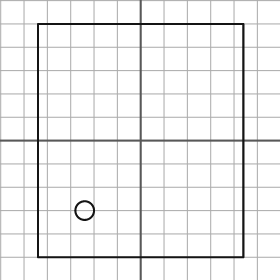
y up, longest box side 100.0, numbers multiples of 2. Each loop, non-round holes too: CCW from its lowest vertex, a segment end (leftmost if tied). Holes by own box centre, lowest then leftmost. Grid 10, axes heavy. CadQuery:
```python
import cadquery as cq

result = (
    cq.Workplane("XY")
    .moveTo(-44.0, -50.0)
    .lineTo(44.0, -50.0)
    .lineTo(44.0, 50.0)
    .lineTo(-44.0, 50.0)
    .close()
    .moveTo(-24.0, -30.0)
    .circle(4.0)
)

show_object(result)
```